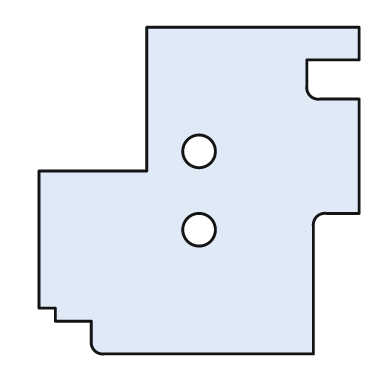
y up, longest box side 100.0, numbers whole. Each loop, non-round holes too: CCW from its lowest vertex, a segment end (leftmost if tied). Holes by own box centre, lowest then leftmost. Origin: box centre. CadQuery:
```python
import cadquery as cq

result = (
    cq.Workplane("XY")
    .moveTo(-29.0, -50.0)
    .lineTo(35.0, -50.0)
    .lineTo(35.0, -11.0)
    .threePointArc((36.0, -8.0), (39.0, -7.0))
    .lineTo(49.0, -7.0)
    .lineTo(49.0, 28.0)
    .lineTo(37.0, 28.0)
    .threePointArc((34.0, 29.0), (33.0, 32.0))
    .lineTo(33.0, 40.0)
    .lineTo(49.0, 40.0)
    .lineTo(49.0, 50.0)
    .lineTo(-16.0, 50.0)
    .lineTo(-16.0, 6.0)
    .lineTo(-49.0, 6.0)
    .lineTo(-49.0, -36.0)
    .lineTo(-44.0, -36.0)
    .lineTo(-44.0, -40.0)
    .lineTo(-33.0, -40.0)
    .lineTo(-33.0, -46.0)
    .threePointArc((-32.0, -49.0), (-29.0, -50.0))
    .close()
    .moveTo(0.0, -12.0)
    .circle(5.0)
    .moveTo(0.0, 12.0)
    .circle(5.0)
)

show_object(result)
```